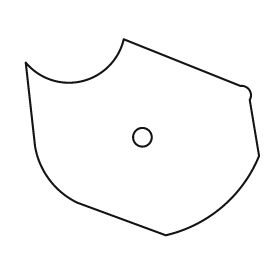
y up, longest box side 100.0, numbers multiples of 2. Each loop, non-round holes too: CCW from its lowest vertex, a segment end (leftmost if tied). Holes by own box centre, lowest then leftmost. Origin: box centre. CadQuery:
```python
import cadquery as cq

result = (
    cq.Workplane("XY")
    .moveTo(10.0, -42.0)
    .threePointArc((34.0, -30.0), (50.0, -8.0))
    .lineTo(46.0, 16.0)
    .threePointArc((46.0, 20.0), (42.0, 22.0))
    .lineTo(-8.0, 42.0)
    .threePointArc((-26.0, 24.0), (-50.0, 32.0))
    .lineTo(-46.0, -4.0)
    .threePointArc((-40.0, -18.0), (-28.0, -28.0))
    .close()
    .moveTo(0.0, 0.0)
    .circle(4.0)
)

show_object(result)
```